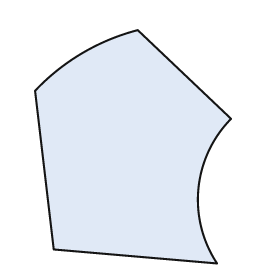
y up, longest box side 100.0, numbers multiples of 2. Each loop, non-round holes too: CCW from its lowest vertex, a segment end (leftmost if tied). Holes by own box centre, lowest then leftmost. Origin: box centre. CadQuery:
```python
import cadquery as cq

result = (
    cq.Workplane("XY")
    .moveTo(36.0, -50.0)
    .threePointArc((28.0, -18.0), (42.0, 12.0))
    .lineTo(2.0, 50.0)
    .threePointArc((-22.0, 40.0), (-42.0, 24.0))
    .lineTo(-34.0, -44.0)
    .close()
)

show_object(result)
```